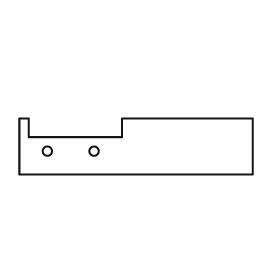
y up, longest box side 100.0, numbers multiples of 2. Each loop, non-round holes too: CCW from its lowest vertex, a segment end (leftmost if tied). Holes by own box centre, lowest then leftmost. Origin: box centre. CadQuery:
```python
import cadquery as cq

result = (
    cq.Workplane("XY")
    .moveTo(-50.0, -12.0)
    .lineTo(50.0, -12.0)
    .lineTo(50.0, 12.0)
    .lineTo(-6.0, 12.0)
    .lineTo(-6.0, 4.0)
    .lineTo(-46.0, 4.0)
    .lineTo(-46.0, 12.0)
    .lineTo(-50.0, 12.0)
    .close()
    .moveTo(-38.0, -2.0)
    .circle(2.0)
    .moveTo(-18.0, -2.0)
    .circle(2.0)
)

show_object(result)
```